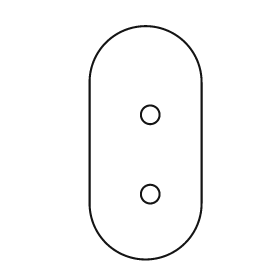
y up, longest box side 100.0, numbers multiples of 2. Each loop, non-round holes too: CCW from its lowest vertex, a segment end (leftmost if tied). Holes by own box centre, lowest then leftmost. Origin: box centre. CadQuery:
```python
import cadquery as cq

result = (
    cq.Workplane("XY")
    .moveTo(-24.0, -26.0)
    .threePointArc((0.0, -50.0), (24.0, -26.0))
    .lineTo(24.0, 26.0)
    .threePointArc((0.0, 50.0), (-24.0, 26.0))
    .close()
    .moveTo(2.0, -22.0)
    .circle(4.0)
    .moveTo(2.0, 12.0)
    .circle(4.0)
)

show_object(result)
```